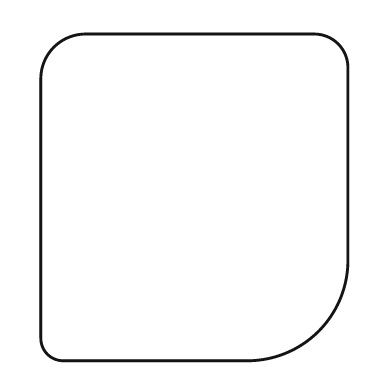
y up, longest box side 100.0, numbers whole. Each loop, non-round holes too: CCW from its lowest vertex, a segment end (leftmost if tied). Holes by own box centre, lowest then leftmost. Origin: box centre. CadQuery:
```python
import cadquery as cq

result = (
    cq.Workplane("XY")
    .moveTo(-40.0, -50.0)
    .lineTo(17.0, -50.0)
    .threePointArc((38.0, -41.0), (47.0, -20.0))
    .lineTo(47.0, 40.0)
    .threePointArc((44.0, 47.0), (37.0, 50.0))
    .lineTo(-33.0, 50.0)
    .threePointArc((-43.0, 46.0), (-47.0, 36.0))
    .lineTo(-47.0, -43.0)
    .threePointArc((-45.0, -48.0), (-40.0, -50.0))
    .close()
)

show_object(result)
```